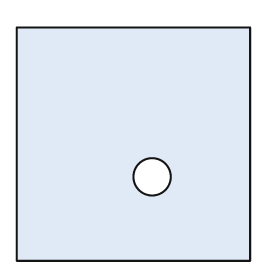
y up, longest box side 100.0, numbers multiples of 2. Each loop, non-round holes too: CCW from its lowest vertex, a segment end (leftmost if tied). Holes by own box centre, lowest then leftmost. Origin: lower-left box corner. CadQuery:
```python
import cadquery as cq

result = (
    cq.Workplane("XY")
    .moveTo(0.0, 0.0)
    .lineTo(100.0, 0.0)
    .lineTo(100.0, 100.0)
    .lineTo(0.0, 100.0)
    .close()
    .moveTo(58.0, 36.0)
    .circle(8.0)
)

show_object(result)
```